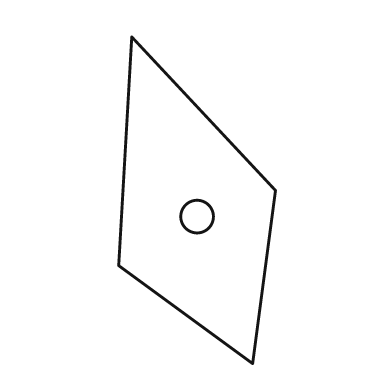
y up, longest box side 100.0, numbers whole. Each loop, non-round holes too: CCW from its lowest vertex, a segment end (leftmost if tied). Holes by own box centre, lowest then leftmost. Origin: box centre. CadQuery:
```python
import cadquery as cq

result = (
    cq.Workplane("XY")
    .moveTo(17.0, -50.0)
    .lineTo(24.0, 3.0)
    .lineTo(-20.0, 50.0)
    .lineTo(-24.0, -20.0)
    .close()
    .moveTo(0.0, -5.0)
    .circle(5.0)
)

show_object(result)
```